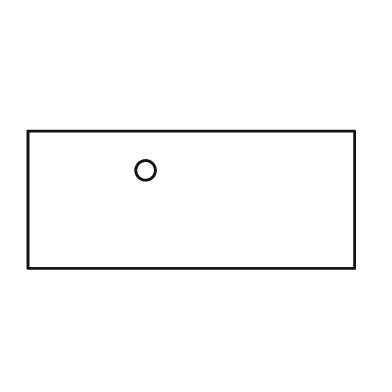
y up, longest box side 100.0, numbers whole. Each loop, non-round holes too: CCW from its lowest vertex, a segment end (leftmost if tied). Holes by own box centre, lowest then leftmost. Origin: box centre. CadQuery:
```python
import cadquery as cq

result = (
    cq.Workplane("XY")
    .moveTo(-50.0, -21.0)
    .lineTo(50.0, -21.0)
    .lineTo(50.0, 21.0)
    .lineTo(-50.0, 21.0)
    .close()
    .moveTo(-14.0, 9.0)
    .circle(3.0)
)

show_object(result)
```